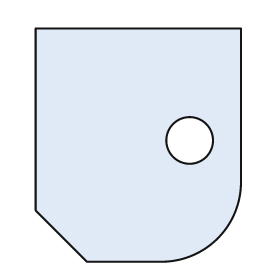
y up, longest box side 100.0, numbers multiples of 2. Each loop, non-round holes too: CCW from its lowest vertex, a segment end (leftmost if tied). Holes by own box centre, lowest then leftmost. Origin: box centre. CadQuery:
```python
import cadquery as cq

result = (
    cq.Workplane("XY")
    .moveTo(-22.0, -50.0)
    .lineTo(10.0, -50.0)
    .threePointArc((34.0, -40.0), (44.0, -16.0))
    .lineTo(44.0, 50.0)
    .lineTo(-44.0, 50.0)
    .lineTo(-44.0, -28.0)
    .close()
    .moveTo(22.0, 2.0)
    .circle(10.0)
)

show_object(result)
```